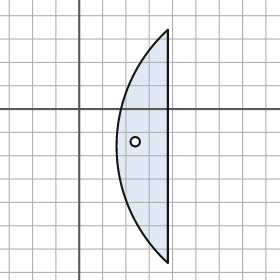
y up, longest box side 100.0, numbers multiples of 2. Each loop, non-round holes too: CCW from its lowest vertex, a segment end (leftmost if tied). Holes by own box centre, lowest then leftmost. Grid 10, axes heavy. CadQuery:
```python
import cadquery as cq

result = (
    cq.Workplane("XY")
    .moveTo(38.0, -66.0)
    .lineTo(38.0, 34.0)
    .threePointArc((16.0, -16.0), (38.0, -66.0))
    .close()
    .moveTo(24.0, -14.0)
    .circle(2.0)
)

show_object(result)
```